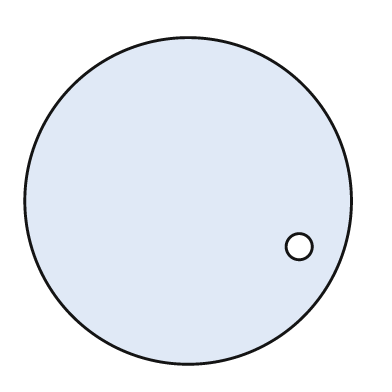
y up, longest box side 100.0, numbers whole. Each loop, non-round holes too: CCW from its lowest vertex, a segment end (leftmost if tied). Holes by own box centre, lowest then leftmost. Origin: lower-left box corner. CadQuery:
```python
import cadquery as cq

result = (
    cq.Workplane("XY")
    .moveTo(50.0, 50.0)
    .circle(50.0)
    .moveTo(84.0, 36.0)
    .circle(4.0)
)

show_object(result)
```